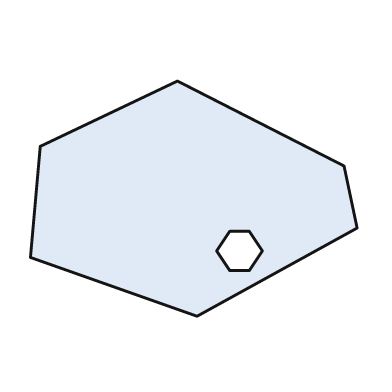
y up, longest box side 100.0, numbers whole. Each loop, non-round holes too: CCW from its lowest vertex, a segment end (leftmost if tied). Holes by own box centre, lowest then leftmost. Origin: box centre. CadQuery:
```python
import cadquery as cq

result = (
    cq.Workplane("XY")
    .moveTo(1.0, -36.0)
    .lineTo(50.0, -9.0)
    .lineTo(46.0, 10.0)
    .lineTo(-5.0, 36.0)
    .lineTo(-47.0, 16.0)
    .lineTo(-50.0, -18.0)
    .close()
    .moveTo(11.0, -22.0)
    .lineTo(17.0, -22.0)
    .lineTo(21.0, -16.0)
    .lineTo(17.0, -10.0)
    .lineTo(11.0, -10.0)
    .lineTo(7.0, -16.0)
    .close()
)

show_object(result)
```